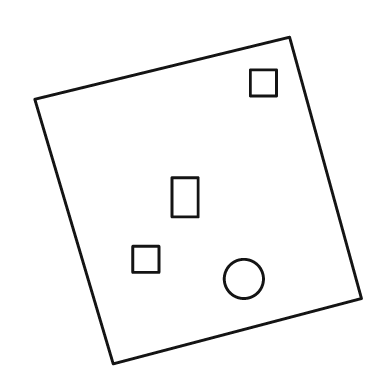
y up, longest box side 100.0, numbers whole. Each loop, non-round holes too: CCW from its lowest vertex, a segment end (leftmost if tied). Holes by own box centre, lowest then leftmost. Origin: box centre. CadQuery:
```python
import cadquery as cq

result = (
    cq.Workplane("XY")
    .moveTo(-26.0, -50.0)
    .lineTo(50.0, -30.0)
    .lineTo(28.0, 50.0)
    .lineTo(-50.0, 31.0)
    .close()
    .moveTo(14.0, -24.0)
    .circle(6.0)
    .moveTo(-20.0, -22.0)
    .lineTo(-12.0, -22.0)
    .lineTo(-12.0, -14.0)
    .lineTo(-20.0, -14.0)
    .close()
    .moveTo(-8.0, -5.0)
    .lineTo(0.0, -5.0)
    .lineTo(0.0, 7.0)
    .lineTo(-8.0, 7.0)
    .close()
    .moveTo(16.0, 32.0)
    .lineTo(24.0, 32.0)
    .lineTo(24.0, 40.0)
    .lineTo(16.0, 40.0)
    .close()
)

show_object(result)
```